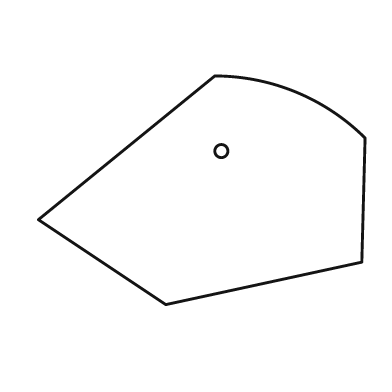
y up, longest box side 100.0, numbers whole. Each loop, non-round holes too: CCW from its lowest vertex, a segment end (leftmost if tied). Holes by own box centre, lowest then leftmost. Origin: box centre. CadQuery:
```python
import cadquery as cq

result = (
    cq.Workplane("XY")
    .moveTo(-11.0, -35.0)
    .lineTo(49.0, -22.0)
    .lineTo(50.0, 16.0)
    .threePointArc((29.0, 30.0), (4.0, 35.0))
    .lineTo(-50.0, -9.0)
    .close()
    .moveTo(6.0, 12.0)
    .circle(2.0)
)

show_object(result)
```